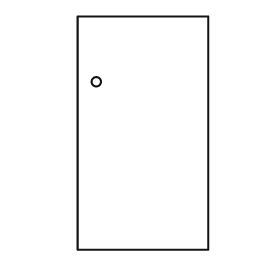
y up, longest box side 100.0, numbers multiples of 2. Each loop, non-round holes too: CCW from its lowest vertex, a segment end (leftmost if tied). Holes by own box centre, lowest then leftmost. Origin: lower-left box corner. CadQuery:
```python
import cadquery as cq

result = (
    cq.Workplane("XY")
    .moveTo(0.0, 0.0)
    .lineTo(56.0, 0.0)
    .lineTo(56.0, 100.0)
    .lineTo(0.0, 100.0)
    .close()
    .moveTo(8.0, 72.0)
    .circle(2.0)
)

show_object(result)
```